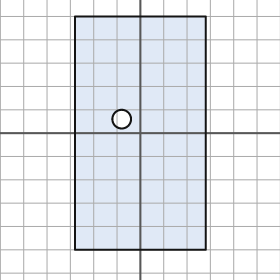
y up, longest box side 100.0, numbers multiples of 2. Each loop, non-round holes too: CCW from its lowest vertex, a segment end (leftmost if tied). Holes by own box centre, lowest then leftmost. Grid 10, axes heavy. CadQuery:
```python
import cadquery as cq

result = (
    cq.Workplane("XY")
    .moveTo(-28.0, -50.0)
    .lineTo(28.0, -50.0)
    .lineTo(28.0, 50.0)
    .lineTo(-28.0, 50.0)
    .close()
    .moveTo(-8.0, 6.0)
    .circle(4.0)
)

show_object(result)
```